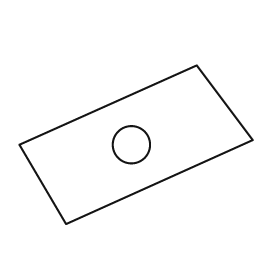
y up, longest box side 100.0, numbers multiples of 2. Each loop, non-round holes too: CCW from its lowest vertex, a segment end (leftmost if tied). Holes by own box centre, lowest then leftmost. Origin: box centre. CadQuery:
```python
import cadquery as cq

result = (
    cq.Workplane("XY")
    .moveTo(-30.0, -34.0)
    .lineTo(50.0, 2.0)
    .lineTo(26.0, 34.0)
    .lineTo(-50.0, 0.0)
    .close()
    .moveTo(-2.0, 0.0)
    .circle(8.0)
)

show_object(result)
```